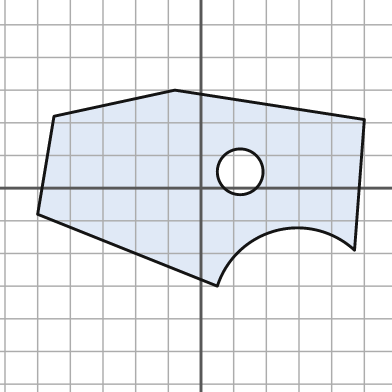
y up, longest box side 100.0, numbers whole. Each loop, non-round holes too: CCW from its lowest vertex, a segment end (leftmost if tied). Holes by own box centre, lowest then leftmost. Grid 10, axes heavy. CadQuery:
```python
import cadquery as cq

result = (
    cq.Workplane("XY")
    .moveTo(5.0, -30.0)
    .threePointArc((23.0, -13.0), (47.0, -19.0))
    .lineTo(50.0, 21.0)
    .lineTo(-8.0, 30.0)
    .lineTo(-45.0, 22.0)
    .lineTo(-50.0, -8.0)
    .close()
    .moveTo(12.0, 5.0)
    .circle(7.0)
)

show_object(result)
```